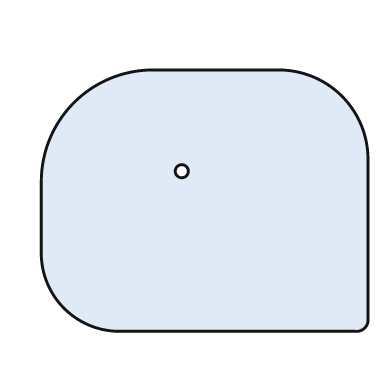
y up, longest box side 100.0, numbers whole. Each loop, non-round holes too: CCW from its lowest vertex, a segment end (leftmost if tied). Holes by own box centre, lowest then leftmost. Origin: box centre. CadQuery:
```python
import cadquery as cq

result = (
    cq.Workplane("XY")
    .moveTo(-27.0, -40.0)
    .lineTo(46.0, -40.0)
    .threePointArc((49.0, -39.0), (50.0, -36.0))
    .lineTo(50.0, 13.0)
    .threePointArc((42.0, 32.0), (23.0, 40.0))
    .lineTo(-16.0, 40.0)
    .threePointArc((-40.0, 30.0), (-50.0, 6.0))
    .lineTo(-50.0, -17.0)
    .threePointArc((-43.0, -33.0), (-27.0, -40.0))
    .close()
    .moveTo(-7.0, 9.0)
    .circle(2.0)
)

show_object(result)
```